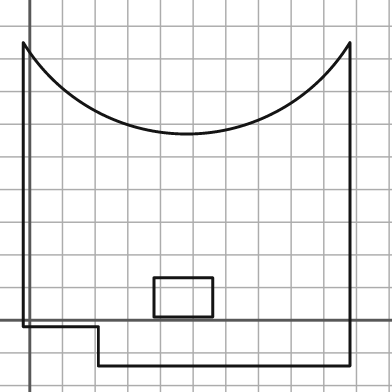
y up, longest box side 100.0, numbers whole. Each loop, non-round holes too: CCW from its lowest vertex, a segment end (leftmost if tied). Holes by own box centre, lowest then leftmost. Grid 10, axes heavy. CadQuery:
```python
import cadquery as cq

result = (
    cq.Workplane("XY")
    .moveTo(21.0, -14.0)
    .lineTo(98.0, -14.0)
    .lineTo(98.0, 85.0)
    .threePointArc((48.0, 57.0), (-2.0, 85.0))
    .lineTo(-2.0, -2.0)
    .lineTo(21.0, -2.0)
    .close()
    .moveTo(38.0, 1.0)
    .lineTo(56.0, 1.0)
    .lineTo(56.0, 13.0)
    .lineTo(38.0, 13.0)
    .close()
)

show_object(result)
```